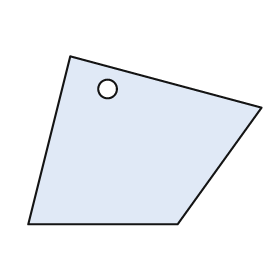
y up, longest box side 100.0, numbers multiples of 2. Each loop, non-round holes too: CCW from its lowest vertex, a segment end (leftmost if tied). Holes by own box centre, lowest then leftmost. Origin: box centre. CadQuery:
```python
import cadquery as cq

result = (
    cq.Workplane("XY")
    .moveTo(-50.0, -36.0)
    .lineTo(14.0, -36.0)
    .lineTo(50.0, 14.0)
    .lineTo(-32.0, 36.0)
    .close()
    .moveTo(-16.0, 22.0)
    .circle(4.0)
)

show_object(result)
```